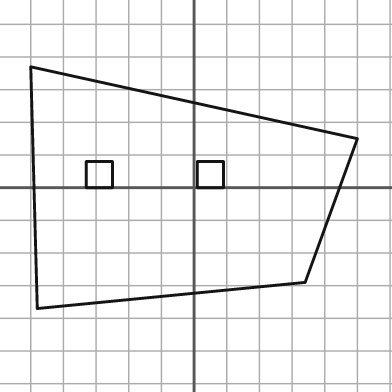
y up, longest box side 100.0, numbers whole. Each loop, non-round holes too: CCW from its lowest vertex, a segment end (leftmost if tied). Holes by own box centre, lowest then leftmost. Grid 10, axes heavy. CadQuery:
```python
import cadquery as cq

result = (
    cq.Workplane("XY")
    .moveTo(-48.0, -37.0)
    .lineTo(34.0, -29.0)
    .lineTo(50.0, 15.0)
    .lineTo(-50.0, 37.0)
    .close()
    .moveTo(-33.0, 0.0)
    .lineTo(-25.0, 0.0)
    .lineTo(-25.0, 8.0)
    .lineTo(-33.0, 8.0)
    .close()
    .moveTo(1.0, 0.0)
    .lineTo(9.0, 0.0)
    .lineTo(9.0, 8.0)
    .lineTo(1.0, 8.0)
    .close()
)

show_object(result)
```